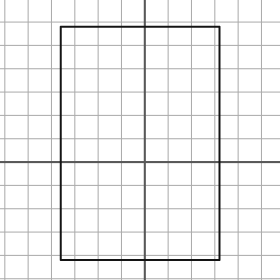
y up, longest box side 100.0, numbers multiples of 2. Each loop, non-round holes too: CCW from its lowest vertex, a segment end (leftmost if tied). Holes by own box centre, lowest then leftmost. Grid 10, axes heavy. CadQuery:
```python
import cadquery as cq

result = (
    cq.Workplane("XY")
    .moveTo(-36.0, -42.0)
    .lineTo(32.0, -42.0)
    .lineTo(32.0, 58.0)
    .lineTo(-36.0, 58.0)
    .close()
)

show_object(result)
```